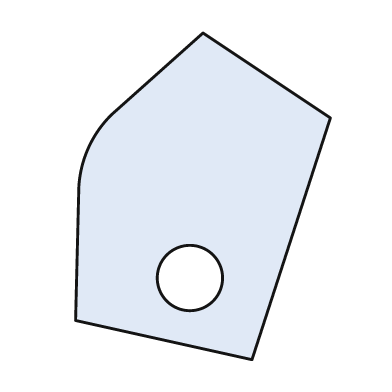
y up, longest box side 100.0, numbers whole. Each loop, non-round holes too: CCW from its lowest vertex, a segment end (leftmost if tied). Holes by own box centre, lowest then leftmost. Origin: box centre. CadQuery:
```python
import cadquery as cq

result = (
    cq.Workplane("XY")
    .moveTo(15.0, -50.0)
    .lineTo(39.0, 24.0)
    .lineTo(0.0, 50.0)
    .lineTo(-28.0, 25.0)
    .threePointArc((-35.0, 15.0), (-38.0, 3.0))
    .lineTo(-39.0, -38.0)
    .close()
    .moveTo(-4.0, -25.0)
    .circle(10.0)
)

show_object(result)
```